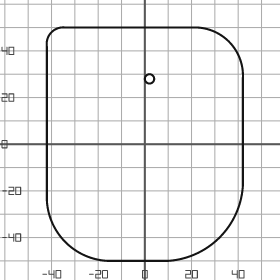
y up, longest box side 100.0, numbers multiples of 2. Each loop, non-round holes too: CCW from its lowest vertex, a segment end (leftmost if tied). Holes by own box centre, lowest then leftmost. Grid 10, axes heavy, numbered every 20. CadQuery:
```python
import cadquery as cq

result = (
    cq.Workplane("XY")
    .moveTo(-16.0, -50.0)
    .lineTo(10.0, -50.0)
    .threePointArc((32.0, -40.0), (42.0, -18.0))
    .lineTo(42.0, 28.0)
    .threePointArc((36.0, 44.0), (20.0, 50.0))
    .lineTo(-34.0, 50.0)
    .threePointArc((-40.0, 48.0), (-42.0, 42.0))
    .lineTo(-42.0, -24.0)
    .threePointArc((-34.0, -42.0), (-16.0, -50.0))
    .close()
    .moveTo(2.0, 28.0)
    .circle(2.0)
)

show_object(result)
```